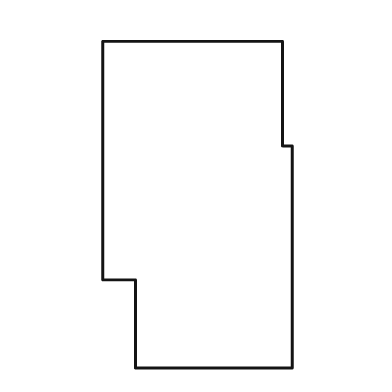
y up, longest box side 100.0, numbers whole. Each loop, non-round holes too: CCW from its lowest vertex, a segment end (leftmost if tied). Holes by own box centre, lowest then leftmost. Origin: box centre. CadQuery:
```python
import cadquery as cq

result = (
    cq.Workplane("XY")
    .moveTo(-19.0, -50.0)
    .lineTo(29.0, -50.0)
    .lineTo(29.0, 18.0)
    .lineTo(26.0, 18.0)
    .lineTo(26.0, 50.0)
    .lineTo(-29.0, 50.0)
    .lineTo(-29.0, -23.0)
    .lineTo(-19.0, -23.0)
    .close()
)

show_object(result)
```